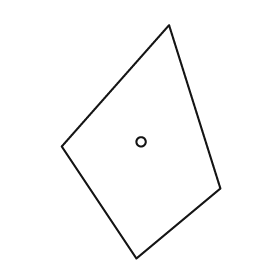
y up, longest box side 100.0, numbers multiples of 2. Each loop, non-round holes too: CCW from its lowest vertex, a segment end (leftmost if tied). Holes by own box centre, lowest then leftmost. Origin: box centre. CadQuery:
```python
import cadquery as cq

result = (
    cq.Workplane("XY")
    .moveTo(-2.0, -50.0)
    .lineTo(34.0, -20.0)
    .lineTo(12.0, 50.0)
    .lineTo(-34.0, -2.0)
    .close()
    .moveTo(0.0, 0.0)
    .circle(2.0)
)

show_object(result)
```